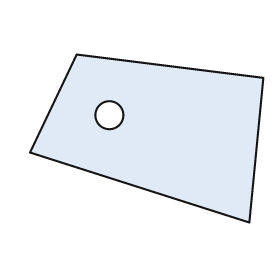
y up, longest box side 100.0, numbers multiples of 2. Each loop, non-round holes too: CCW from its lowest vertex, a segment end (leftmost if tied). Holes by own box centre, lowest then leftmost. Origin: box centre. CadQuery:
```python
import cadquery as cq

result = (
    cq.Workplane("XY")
    .moveTo(44.0, -36.0)
    .lineTo(50.0, 26.0)
    .lineTo(-30.0, 36.0)
    .lineTo(-50.0, -6.0)
    .close()
    .moveTo(-16.0, 10.0)
    .circle(6.0)
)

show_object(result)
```